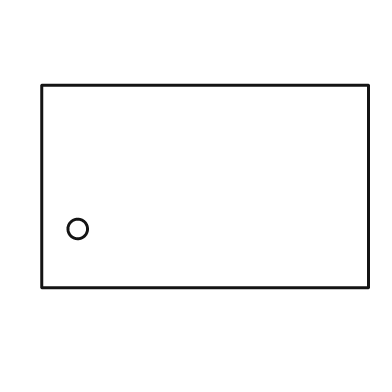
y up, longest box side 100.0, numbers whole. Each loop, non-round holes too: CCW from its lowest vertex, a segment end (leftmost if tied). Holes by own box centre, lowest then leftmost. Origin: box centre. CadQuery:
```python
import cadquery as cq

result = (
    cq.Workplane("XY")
    .moveTo(-50.0, -31.0)
    .lineTo(50.0, -31.0)
    .lineTo(50.0, 31.0)
    .lineTo(-50.0, 31.0)
    .close()
    .moveTo(-39.0, -13.0)
    .circle(3.0)
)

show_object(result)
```